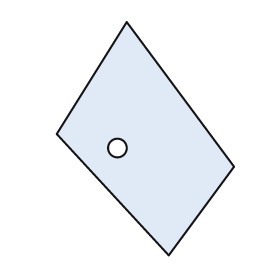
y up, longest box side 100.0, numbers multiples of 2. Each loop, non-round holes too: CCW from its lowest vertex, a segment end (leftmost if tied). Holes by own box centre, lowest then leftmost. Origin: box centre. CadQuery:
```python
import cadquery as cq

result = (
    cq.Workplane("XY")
    .moveTo(10.0, -50.0)
    .lineTo(38.0, -12.0)
    .lineTo(-8.0, 50.0)
    .lineTo(-38.0, 2.0)
    .close()
    .moveTo(-12.0, -4.0)
    .circle(4.0)
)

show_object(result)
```